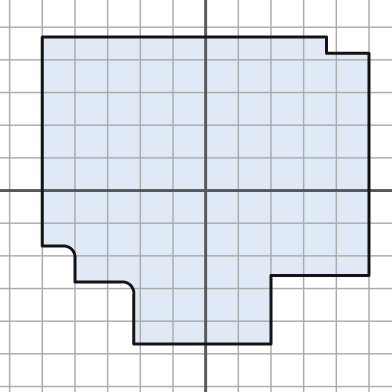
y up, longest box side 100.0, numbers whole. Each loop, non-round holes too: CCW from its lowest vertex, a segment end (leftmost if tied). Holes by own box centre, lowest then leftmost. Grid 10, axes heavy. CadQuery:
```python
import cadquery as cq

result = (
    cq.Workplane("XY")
    .moveTo(-22.0, -47.0)
    .lineTo(20.0, -47.0)
    .lineTo(20.0, -26.0)
    .lineTo(50.0, -26.0)
    .lineTo(50.0, 42.0)
    .lineTo(37.0, 42.0)
    .lineTo(37.0, 47.0)
    .lineTo(-50.0, 47.0)
    .lineTo(-50.0, -17.0)
    .lineTo(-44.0, -17.0)
    .threePointArc((-41.0, -18.0), (-40.0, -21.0))
    .lineTo(-40.0, -28.0)
    .lineTo(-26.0, -28.0)
    .threePointArc((-23.0, -29.0), (-22.0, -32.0))
    .close()
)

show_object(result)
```